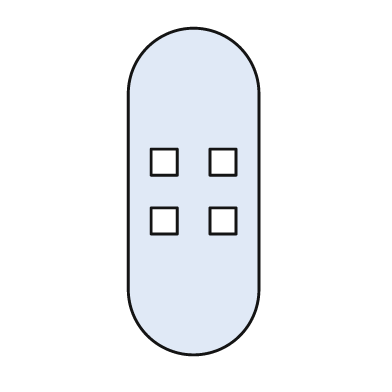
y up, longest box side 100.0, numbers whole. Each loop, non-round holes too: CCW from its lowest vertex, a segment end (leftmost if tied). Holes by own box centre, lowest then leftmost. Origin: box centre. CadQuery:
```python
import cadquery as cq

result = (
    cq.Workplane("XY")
    .moveTo(-20.0, -30.0)
    .threePointArc((0.0, -50.0), (20.0, -30.0))
    .lineTo(20.0, 30.0)
    .threePointArc((0.0, 50.0), (-20.0, 30.0))
    .close()
    .moveTo(-13.0, -13.0)
    .lineTo(-5.0, -13.0)
    .lineTo(-5.0, -5.0)
    .lineTo(-13.0, -5.0)
    .close()
    .moveTo(5.0, -13.0)
    .lineTo(13.0, -13.0)
    .lineTo(13.0, -5.0)
    .lineTo(5.0, -5.0)
    .close()
    .moveTo(-13.0, 5.0)
    .lineTo(-5.0, 5.0)
    .lineTo(-5.0, 13.0)
    .lineTo(-13.0, 13.0)
    .close()
    .moveTo(5.0, 5.0)
    .lineTo(13.0, 5.0)
    .lineTo(13.0, 13.0)
    .lineTo(5.0, 13.0)
    .close()
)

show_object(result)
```